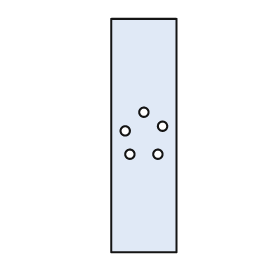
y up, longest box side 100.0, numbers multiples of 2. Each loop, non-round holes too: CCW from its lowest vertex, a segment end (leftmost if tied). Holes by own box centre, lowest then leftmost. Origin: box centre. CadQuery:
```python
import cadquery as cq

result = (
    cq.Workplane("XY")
    .moveTo(-14.0, -50.0)
    .lineTo(14.0, -50.0)
    .lineTo(14.0, 50.0)
    .lineTo(-14.0, 50.0)
    .close()
    .moveTo(-6.0, -8.0)
    .circle(2.0)
    .moveTo(6.0, -8.0)
    .circle(2.0)
    .moveTo(-8.0, 2.0)
    .circle(2.0)
    .moveTo(8.0, 4.0)
    .circle(2.0)
    .moveTo(0.0, 10.0)
    .circle(2.0)
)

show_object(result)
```